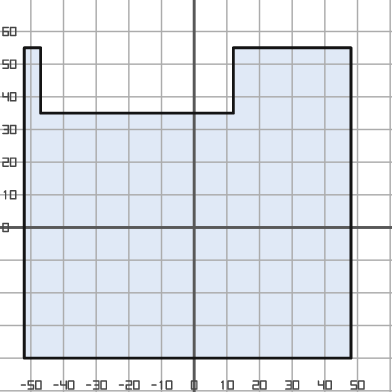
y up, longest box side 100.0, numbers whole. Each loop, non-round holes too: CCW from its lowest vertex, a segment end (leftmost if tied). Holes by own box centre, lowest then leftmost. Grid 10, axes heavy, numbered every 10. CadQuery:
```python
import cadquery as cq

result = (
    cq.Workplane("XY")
    .moveTo(-52.0, -40.0)
    .lineTo(48.0, -40.0)
    .lineTo(48.0, 55.0)
    .lineTo(12.0, 55.0)
    .lineTo(12.0, 35.0)
    .lineTo(-47.0, 35.0)
    .lineTo(-47.0, 55.0)
    .lineTo(-52.0, 55.0)
    .close()
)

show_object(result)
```